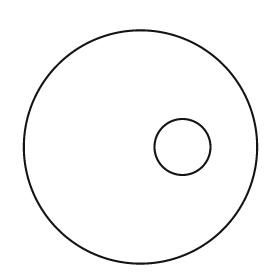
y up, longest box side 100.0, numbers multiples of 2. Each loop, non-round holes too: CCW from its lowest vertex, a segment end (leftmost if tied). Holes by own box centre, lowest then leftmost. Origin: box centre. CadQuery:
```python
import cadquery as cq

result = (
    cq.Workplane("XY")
    .moveTo(0.0, 0.0)
    .circle(50.0)
    .moveTo(18.0, 0.0)
    .circle(12.0)
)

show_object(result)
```